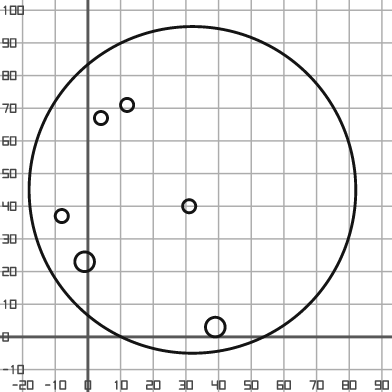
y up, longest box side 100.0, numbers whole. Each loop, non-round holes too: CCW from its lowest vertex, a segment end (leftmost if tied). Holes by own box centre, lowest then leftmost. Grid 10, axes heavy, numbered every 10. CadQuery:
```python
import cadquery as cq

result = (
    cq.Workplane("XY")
    .moveTo(32.0, 45.0)
    .circle(50.0)
    .moveTo(39.0, 3.0)
    .circle(3.0)
    .moveTo(-1.0, 23.0)
    .circle(3.0)
    .moveTo(-8.0, 37.0)
    .circle(2.0)
    .moveTo(31.0, 40.0)
    .circle(2.0)
    .moveTo(4.0, 67.0)
    .circle(2.0)
    .moveTo(12.0, 71.0)
    .circle(2.0)
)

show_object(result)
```